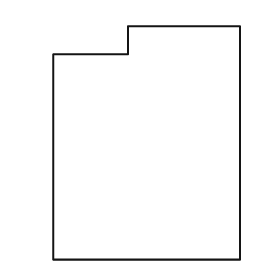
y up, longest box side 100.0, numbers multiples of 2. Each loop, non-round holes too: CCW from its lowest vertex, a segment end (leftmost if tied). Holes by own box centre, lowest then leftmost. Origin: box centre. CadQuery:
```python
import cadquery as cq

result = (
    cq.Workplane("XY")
    .moveTo(-40.0, -50.0)
    .lineTo(40.0, -50.0)
    .lineTo(40.0, 50.0)
    .lineTo(-8.0, 50.0)
    .lineTo(-8.0, 38.0)
    .lineTo(-40.0, 38.0)
    .close()
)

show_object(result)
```